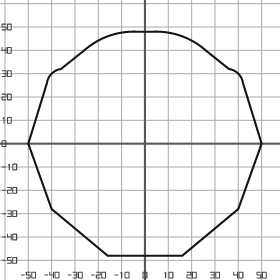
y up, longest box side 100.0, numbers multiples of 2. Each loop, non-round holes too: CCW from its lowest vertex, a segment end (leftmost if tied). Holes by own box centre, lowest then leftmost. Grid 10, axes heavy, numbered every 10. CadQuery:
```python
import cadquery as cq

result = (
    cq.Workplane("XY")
    .moveTo(-16.0, -48.0)
    .lineTo(16.0, -48.0)
    .lineTo(40.0, -28.0)
    .lineTo(50.0, 0.0)
    .lineTo(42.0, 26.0)
    .threePointArc((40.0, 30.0), (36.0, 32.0))
    .lineTo(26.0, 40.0)
    .threePointArc((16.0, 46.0), (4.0, 48.0))
    .lineTo(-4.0, 48.0)
    .threePointArc((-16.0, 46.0), (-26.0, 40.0))
    .lineTo(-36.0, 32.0)
    .threePointArc((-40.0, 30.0), (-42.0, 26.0))
    .lineTo(-50.0, 0.0)
    .lineTo(-40.0, -28.0)
    .close()
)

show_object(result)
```